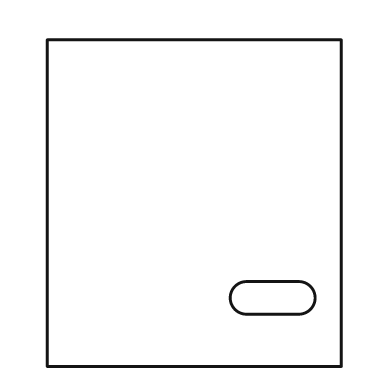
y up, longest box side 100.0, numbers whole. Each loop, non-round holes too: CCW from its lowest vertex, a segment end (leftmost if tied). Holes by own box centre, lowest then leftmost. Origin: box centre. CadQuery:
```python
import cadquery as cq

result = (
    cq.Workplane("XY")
    .moveTo(-45.0, -50.0)
    .lineTo(45.0, -50.0)
    .lineTo(45.0, 50.0)
    .lineTo(-45.0, 50.0)
    .close()
    .moveTo(16.0, -34.0)
    .lineTo(32.0, -34.0)
    .threePointArc((37.0, -29.0), (32.0, -24.0))
    .lineTo(16.0, -24.0)
    .threePointArc((11.0, -29.0), (16.0, -34.0))
    .close()
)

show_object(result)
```